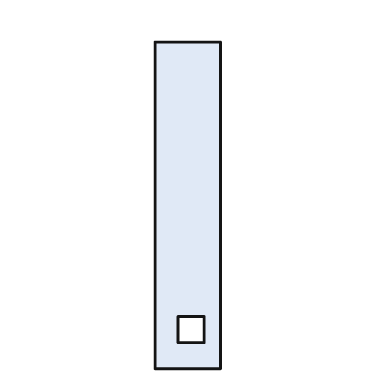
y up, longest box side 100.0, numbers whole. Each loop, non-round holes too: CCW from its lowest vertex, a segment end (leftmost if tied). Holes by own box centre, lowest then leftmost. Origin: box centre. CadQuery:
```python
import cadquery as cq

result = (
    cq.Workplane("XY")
    .moveTo(-10.0, -50.0)
    .lineTo(10.0, -50.0)
    .lineTo(10.0, 50.0)
    .lineTo(-10.0, 50.0)
    .close()
    .moveTo(-3.0, -42.0)
    .lineTo(5.0, -42.0)
    .lineTo(5.0, -34.0)
    .lineTo(-3.0, -34.0)
    .close()
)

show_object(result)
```